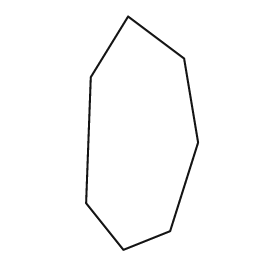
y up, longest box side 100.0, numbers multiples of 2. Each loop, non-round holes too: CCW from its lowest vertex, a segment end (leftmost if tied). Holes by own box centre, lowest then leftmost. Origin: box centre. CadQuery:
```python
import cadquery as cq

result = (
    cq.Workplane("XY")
    .moveTo(-8.0, -50.0)
    .lineTo(12.0, -42.0)
    .lineTo(24.0, -4.0)
    .lineTo(18.0, 32.0)
    .lineTo(-6.0, 50.0)
    .lineTo(-22.0, 24.0)
    .lineTo(-24.0, -30.0)
    .close()
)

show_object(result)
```